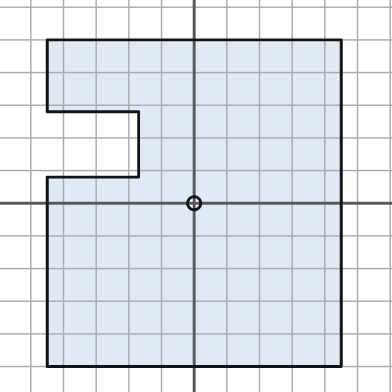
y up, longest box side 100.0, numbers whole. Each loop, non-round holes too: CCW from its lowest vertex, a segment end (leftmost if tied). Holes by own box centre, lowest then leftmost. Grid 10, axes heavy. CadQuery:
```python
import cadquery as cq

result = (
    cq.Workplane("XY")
    .moveTo(-45.0, -50.0)
    .lineTo(45.0, -50.0)
    .lineTo(45.0, 50.0)
    .lineTo(-45.0, 50.0)
    .lineTo(-45.0, 28.0)
    .lineTo(-17.0, 28.0)
    .lineTo(-17.0, 8.0)
    .lineTo(-45.0, 8.0)
    .close()
    .moveTo(0.0, 0.0)
    .circle(2.0)
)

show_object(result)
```